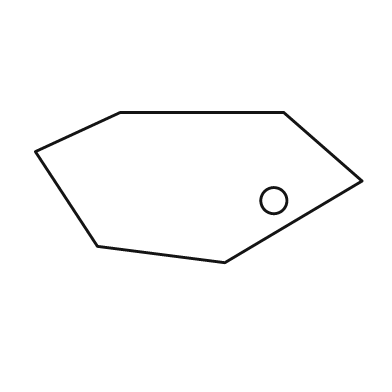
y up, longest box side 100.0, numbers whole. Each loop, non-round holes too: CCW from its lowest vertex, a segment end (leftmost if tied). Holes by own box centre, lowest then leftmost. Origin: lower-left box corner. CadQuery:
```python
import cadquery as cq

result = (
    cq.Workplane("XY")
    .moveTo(58.0, 0.0)
    .lineTo(100.0, 25.0)
    .lineTo(76.0, 46.0)
    .lineTo(26.0, 46.0)
    .lineTo(0.0, 34.0)
    .lineTo(19.0, 5.0)
    .close()
    .moveTo(73.0, 19.0)
    .circle(4.0)
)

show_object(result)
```